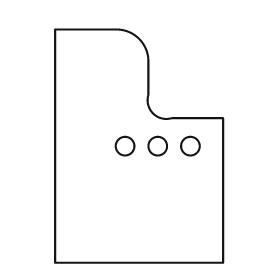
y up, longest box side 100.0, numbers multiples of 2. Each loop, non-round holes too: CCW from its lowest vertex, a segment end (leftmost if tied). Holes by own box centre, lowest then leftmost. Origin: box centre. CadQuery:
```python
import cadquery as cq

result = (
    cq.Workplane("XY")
    .moveTo(-36.0, -50.0)
    .lineTo(36.0, -50.0)
    .lineTo(36.0, 12.0)
    .lineTo(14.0, 12.0)
    .threePointArc((6.0, 14.0), (4.0, 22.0))
    .lineTo(4.0, 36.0)
    .threePointArc((0.0, 46.0), (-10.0, 50.0))
    .lineTo(-36.0, 50.0)
    .close()
    .moveTo(-6.0, 0.0)
    .circle(4.0)
    .moveTo(8.0, 0.0)
    .circle(4.0)
    .moveTo(22.0, 0.0)
    .circle(4.0)
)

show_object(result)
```